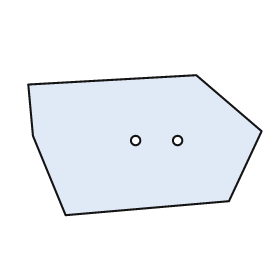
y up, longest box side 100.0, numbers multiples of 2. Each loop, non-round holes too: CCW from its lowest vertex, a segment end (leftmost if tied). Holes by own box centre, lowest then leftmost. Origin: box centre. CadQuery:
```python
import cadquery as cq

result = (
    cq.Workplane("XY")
    .moveTo(-34.0, -30.0)
    .lineTo(36.0, -24.0)
    .lineTo(50.0, 6.0)
    .lineTo(22.0, 30.0)
    .lineTo(-50.0, 26.0)
    .lineTo(-48.0, 4.0)
    .close()
    .moveTo(-4.0, 2.0)
    .circle(2.0)
    .moveTo(14.0, 2.0)
    .circle(2.0)
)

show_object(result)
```